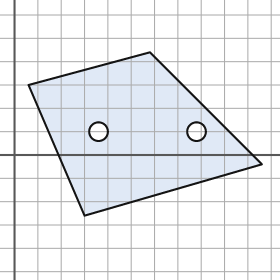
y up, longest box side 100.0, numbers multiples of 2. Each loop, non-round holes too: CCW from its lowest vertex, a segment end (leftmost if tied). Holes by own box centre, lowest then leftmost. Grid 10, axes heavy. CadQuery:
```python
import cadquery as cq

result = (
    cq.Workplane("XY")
    .moveTo(30.0, -26.0)
    .lineTo(106.0, -4.0)
    .lineTo(58.0, 44.0)
    .lineTo(6.0, 30.0)
    .close()
    .moveTo(36.0, 10.0)
    .circle(4.0)
    .moveTo(78.0, 10.0)
    .circle(4.0)
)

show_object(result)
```